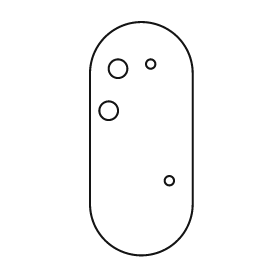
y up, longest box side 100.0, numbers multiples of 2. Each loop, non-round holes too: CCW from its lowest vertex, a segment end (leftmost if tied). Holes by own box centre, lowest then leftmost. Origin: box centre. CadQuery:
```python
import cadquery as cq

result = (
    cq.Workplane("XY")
    .moveTo(-22.0, -28.0)
    .threePointArc((0.0, -50.0), (22.0, -28.0))
    .lineTo(22.0, 28.0)
    .threePointArc((0.0, 50.0), (-22.0, 28.0))
    .close()
    .moveTo(12.0, -18.0)
    .circle(2.0)
    .moveTo(-14.0, 12.0)
    .circle(4.0)
    .moveTo(-10.0, 30.0)
    .circle(4.0)
    .moveTo(4.0, 32.0)
    .circle(2.0)
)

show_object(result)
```